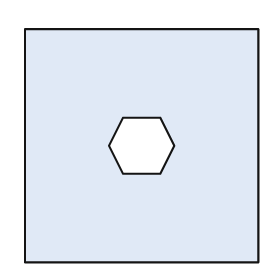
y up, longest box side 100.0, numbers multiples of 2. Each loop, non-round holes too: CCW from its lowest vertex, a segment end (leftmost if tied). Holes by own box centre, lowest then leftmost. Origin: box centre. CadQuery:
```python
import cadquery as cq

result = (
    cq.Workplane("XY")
    .moveTo(-50.0, -50.0)
    .lineTo(50.0, -50.0)
    .lineTo(50.0, 50.0)
    .lineTo(-50.0, 50.0)
    .close()
    .moveTo(-8.0, -12.0)
    .lineTo(8.0, -12.0)
    .lineTo(14.0, 0.0)
    .lineTo(8.0, 12.0)
    .lineTo(-8.0, 12.0)
    .lineTo(-14.0, 0.0)
    .close()
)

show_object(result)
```